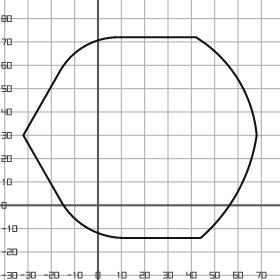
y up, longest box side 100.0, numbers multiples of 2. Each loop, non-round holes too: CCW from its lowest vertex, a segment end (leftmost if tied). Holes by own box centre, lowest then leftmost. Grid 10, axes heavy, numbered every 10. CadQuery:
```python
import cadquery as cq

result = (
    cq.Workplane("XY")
    .moveTo(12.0, -14.0)
    .lineTo(44.0, -14.0)
    .threePointArc((60.0, 6.0), (68.0, 30.0))
    .threePointArc((60.0, 54.0), (42.0, 72.0))
    .lineTo(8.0, 72.0)
    .threePointArc((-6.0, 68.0), (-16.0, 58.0))
    .lineTo(-32.0, 30.0)
    .lineTo(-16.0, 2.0)
    .threePointArc((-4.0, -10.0), (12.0, -14.0))
    .close()
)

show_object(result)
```